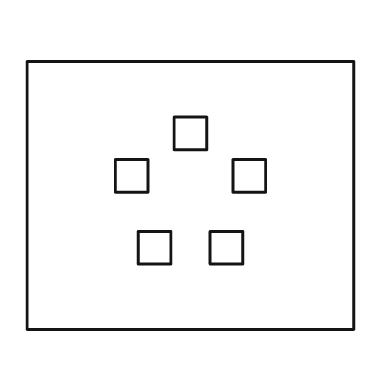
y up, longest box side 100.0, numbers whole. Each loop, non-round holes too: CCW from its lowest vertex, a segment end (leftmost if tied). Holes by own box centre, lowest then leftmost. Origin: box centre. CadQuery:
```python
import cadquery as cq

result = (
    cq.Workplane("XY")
    .moveTo(-50.0, -41.0)
    .lineTo(50.0, -41.0)
    .lineTo(50.0, 41.0)
    .lineTo(-50.0, 41.0)
    .close()
    .moveTo(-16.0, -21.0)
    .lineTo(-6.0, -21.0)
    .lineTo(-6.0, -11.0)
    .lineTo(-16.0, -11.0)
    .close()
    .moveTo(6.0, -21.0)
    .lineTo(16.0, -21.0)
    .lineTo(16.0, -11.0)
    .lineTo(6.0, -11.0)
    .close()
    .moveTo(-23.0, 1.0)
    .lineTo(-13.0, 1.0)
    .lineTo(-13.0, 11.0)
    .lineTo(-23.0, 11.0)
    .close()
    .moveTo(13.0, 1.0)
    .lineTo(23.0, 1.0)
    .lineTo(23.0, 11.0)
    .lineTo(13.0, 11.0)
    .close()
    .moveTo(-5.0, 14.0)
    .lineTo(5.0, 14.0)
    .lineTo(5.0, 24.0)
    .lineTo(-5.0, 24.0)
    .close()
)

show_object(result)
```